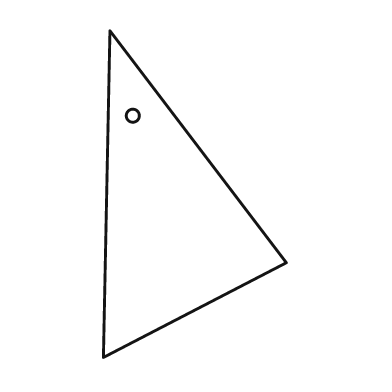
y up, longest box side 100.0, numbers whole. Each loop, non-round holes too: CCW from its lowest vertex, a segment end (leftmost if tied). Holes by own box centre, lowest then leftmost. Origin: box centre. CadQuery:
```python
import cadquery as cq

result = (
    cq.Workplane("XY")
    .moveTo(-28.0, -50.0)
    .lineTo(28.0, -21.0)
    .lineTo(-26.0, 50.0)
    .close()
    .moveTo(-19.0, 24.0)
    .circle(2.0)
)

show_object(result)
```